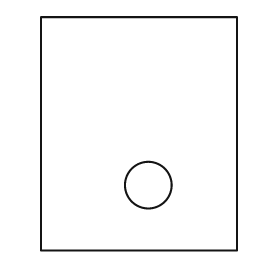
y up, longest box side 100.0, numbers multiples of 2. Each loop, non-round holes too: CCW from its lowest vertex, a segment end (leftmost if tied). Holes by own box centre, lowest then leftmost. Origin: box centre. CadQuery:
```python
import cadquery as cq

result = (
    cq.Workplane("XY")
    .moveTo(-42.0, -50.0)
    .lineTo(42.0, -50.0)
    .lineTo(42.0, 50.0)
    .lineTo(-42.0, 50.0)
    .close()
    .moveTo(4.0, -22.0)
    .circle(10.0)
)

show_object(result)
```